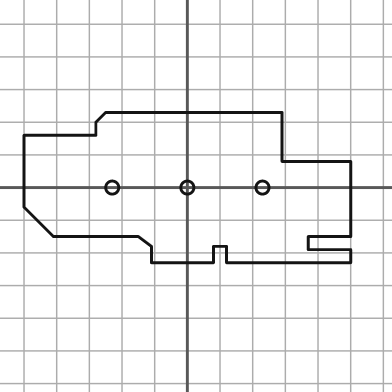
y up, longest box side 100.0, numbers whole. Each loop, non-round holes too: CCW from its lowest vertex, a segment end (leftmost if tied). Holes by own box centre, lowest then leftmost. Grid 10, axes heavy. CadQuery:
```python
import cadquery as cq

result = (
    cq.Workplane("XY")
    .moveTo(-11.0, -23.0)
    .lineTo(8.0, -23.0)
    .lineTo(8.0, -18.0)
    .lineTo(12.0, -18.0)
    .lineTo(12.0, -23.0)
    .lineTo(50.0, -23.0)
    .lineTo(50.0, -19.0)
    .lineTo(37.0, -19.0)
    .lineTo(37.0, -15.0)
    .lineTo(50.0, -15.0)
    .lineTo(50.0, 8.0)
    .lineTo(29.0, 8.0)
    .lineTo(29.0, 23.0)
    .lineTo(-25.0, 23.0)
    .lineTo(-28.0, 20.0)
    .lineTo(-28.0, 16.0)
    .lineTo(-50.0, 16.0)
    .lineTo(-50.0, -6.0)
    .lineTo(-41.0, -15.0)
    .lineTo(-15.0, -15.0)
    .lineTo(-11.0, -18.0)
    .close()
    .moveTo(-23.0, 0.0)
    .circle(2.0)
    .moveTo(0.0, 0.0)
    .circle(2.0)
    .moveTo(23.0, 0.0)
    .circle(2.0)
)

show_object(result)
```